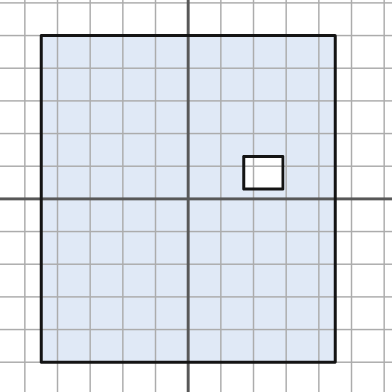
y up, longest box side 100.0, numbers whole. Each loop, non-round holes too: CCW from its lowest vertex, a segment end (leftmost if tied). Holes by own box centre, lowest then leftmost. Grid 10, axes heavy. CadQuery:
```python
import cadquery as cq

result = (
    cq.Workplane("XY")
    .moveTo(-45.0, -50.0)
    .lineTo(45.0, -50.0)
    .lineTo(45.0, 50.0)
    .lineTo(-45.0, 50.0)
    .close()
    .moveTo(17.0, 3.0)
    .lineTo(29.0, 3.0)
    .lineTo(29.0, 13.0)
    .lineTo(17.0, 13.0)
    .close()
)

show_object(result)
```